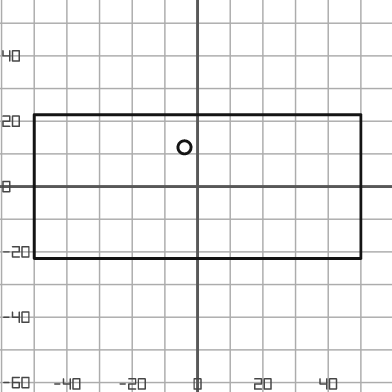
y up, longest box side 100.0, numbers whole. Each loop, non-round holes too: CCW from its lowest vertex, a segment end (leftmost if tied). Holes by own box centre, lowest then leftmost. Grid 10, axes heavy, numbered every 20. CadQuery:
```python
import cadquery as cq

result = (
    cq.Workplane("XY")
    .moveTo(-50.0, -22.0)
    .lineTo(50.0, -22.0)
    .lineTo(50.0, 22.0)
    .lineTo(-50.0, 22.0)
    .close()
    .moveTo(-4.0, 12.0)
    .circle(2.0)
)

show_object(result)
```